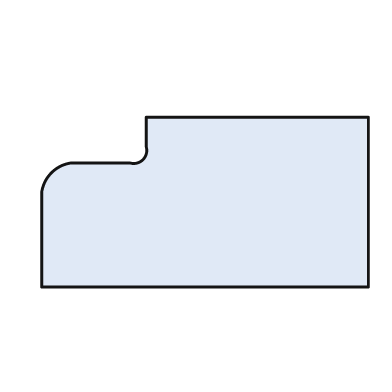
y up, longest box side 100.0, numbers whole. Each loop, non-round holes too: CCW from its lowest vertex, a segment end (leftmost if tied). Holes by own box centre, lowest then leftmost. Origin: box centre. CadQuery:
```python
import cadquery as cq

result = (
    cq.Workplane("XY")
    .moveTo(-50.0, -26.0)
    .lineTo(50.0, -26.0)
    .lineTo(50.0, 26.0)
    .lineTo(-18.0, 26.0)
    .lineTo(-18.0, 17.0)
    .threePointArc((-19.0, 13.0), (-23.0, 12.0))
    .lineTo(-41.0, 12.0)
    .threePointArc((-47.0, 9.0), (-50.0, 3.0))
    .close()
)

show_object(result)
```